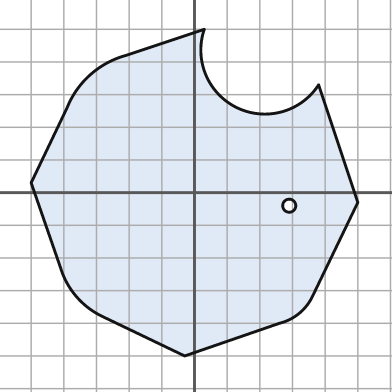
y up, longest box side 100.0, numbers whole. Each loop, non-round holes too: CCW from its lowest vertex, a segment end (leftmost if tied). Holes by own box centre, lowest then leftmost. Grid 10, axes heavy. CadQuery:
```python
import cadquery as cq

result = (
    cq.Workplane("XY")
    .moveTo(-3.0, -50.0)
    .lineTo(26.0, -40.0)
    .threePointArc((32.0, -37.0), (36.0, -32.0))
    .lineTo(50.0, -3.0)
    .lineTo(38.0, 33.0)
    .threePointArc((13.0, 26.0), (3.0, 50.0))
    .lineTo(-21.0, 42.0)
    .threePointArc((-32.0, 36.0), (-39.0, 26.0))
    .lineTo(-50.0, 3.0)
    .lineTo(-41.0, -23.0)
    .threePointArc((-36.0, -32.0), (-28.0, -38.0))
    .close()
    .moveTo(29.0, -4.0)
    .circle(2.0)
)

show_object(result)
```